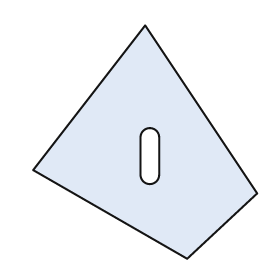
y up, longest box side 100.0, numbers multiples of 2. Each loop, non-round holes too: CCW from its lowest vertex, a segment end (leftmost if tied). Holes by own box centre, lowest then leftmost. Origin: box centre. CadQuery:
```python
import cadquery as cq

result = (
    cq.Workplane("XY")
    .moveTo(18.0, -50.0)
    .lineTo(48.0, -22.0)
    .lineTo(0.0, 50.0)
    .lineTo(-48.0, -12.0)
    .close()
    .moveTo(-2.0, -14.0)
    .threePointArc((2.0, -18.0), (6.0, -14.0))
    .lineTo(6.0, 2.0)
    .threePointArc((2.0, 6.0), (-2.0, 2.0))
    .close()
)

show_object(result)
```